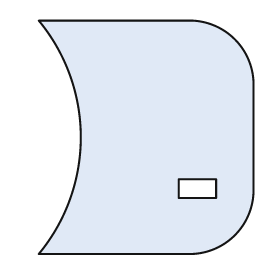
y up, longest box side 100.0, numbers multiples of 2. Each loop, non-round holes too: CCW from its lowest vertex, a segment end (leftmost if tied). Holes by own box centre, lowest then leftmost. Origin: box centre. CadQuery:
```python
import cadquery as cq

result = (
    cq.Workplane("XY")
    .moveTo(-46.0, -50.0)
    .lineTo(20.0, -50.0)
    .threePointArc((38.0, -42.0), (46.0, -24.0))
    .lineTo(46.0, 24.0)
    .threePointArc((38.0, 42.0), (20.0, 50.0))
    .lineTo(-46.0, 50.0)
    .threePointArc((-28.0, 0.0), (-46.0, -50.0))
    .close()
    .moveTo(14.0, -26.0)
    .lineTo(30.0, -26.0)
    .lineTo(30.0, -18.0)
    .lineTo(14.0, -18.0)
    .close()
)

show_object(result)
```